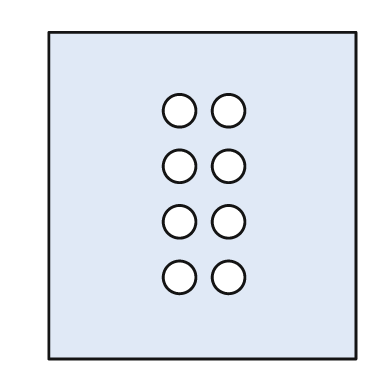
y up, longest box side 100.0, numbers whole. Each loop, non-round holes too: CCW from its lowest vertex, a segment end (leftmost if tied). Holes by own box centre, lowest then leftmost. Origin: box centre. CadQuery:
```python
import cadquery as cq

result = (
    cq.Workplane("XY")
    .moveTo(-47.0, -50.0)
    .lineTo(47.0, -50.0)
    .lineTo(47.0, 50.0)
    .lineTo(-47.0, 50.0)
    .close()
    .moveTo(-7.0, -25.0)
    .circle(5.0)
    .moveTo(8.0, -25.0)
    .circle(5.0)
    .moveTo(-7.0, -8.0)
    .circle(5.0)
    .moveTo(8.0, -8.0)
    .circle(5.0)
    .moveTo(-7.0, 9.0)
    .circle(5.0)
    .moveTo(8.0, 9.0)
    .circle(5.0)
    .moveTo(-7.0, 26.0)
    .circle(5.0)
    .moveTo(8.0, 26.0)
    .circle(5.0)
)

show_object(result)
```